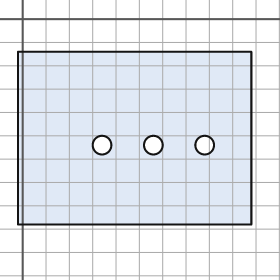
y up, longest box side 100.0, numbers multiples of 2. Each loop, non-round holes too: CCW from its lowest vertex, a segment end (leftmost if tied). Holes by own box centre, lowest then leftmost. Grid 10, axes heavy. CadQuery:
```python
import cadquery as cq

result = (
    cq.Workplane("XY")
    .moveTo(-2.0, -88.0)
    .lineTo(98.0, -88.0)
    .lineTo(98.0, -14.0)
    .lineTo(-2.0, -14.0)
    .close()
    .moveTo(34.0, -54.0)
    .circle(4.0)
    .moveTo(56.0, -54.0)
    .circle(4.0)
    .moveTo(78.0, -54.0)
    .circle(4.0)
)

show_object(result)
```